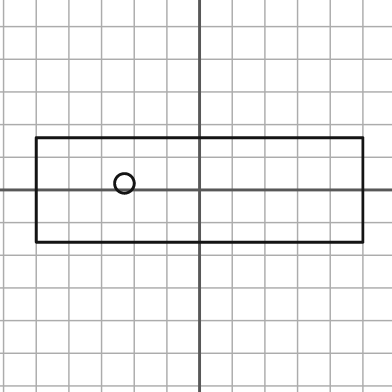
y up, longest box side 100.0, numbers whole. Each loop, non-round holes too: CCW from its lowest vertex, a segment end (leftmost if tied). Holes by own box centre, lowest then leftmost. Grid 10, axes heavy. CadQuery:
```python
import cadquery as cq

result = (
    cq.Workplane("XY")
    .moveTo(-50.0, -16.0)
    .lineTo(50.0, -16.0)
    .lineTo(50.0, 16.0)
    .lineTo(-50.0, 16.0)
    .close()
    .moveTo(-23.0, 2.0)
    .circle(3.0)
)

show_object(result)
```